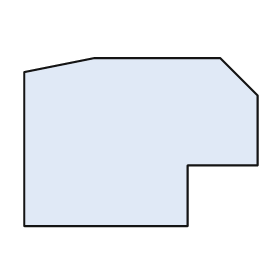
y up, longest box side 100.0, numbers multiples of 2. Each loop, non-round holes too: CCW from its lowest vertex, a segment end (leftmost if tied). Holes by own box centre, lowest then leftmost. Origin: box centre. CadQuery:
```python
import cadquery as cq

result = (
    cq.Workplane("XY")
    .moveTo(-50.0, -36.0)
    .lineTo(20.0, -36.0)
    .lineTo(20.0, -10.0)
    .lineTo(50.0, -10.0)
    .lineTo(50.0, 20.0)
    .lineTo(34.0, 36.0)
    .lineTo(-20.0, 36.0)
    .lineTo(-50.0, 30.0)
    .close()
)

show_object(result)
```